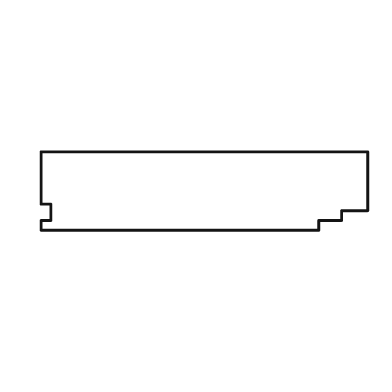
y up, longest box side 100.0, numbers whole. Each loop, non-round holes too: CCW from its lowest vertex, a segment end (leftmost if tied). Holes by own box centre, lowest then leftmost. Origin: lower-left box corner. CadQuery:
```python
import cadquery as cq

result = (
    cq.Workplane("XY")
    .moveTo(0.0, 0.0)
    .lineTo(85.0, 0.0)
    .lineTo(85.0, 3.0)
    .lineTo(92.0, 3.0)
    .lineTo(92.0, 6.0)
    .lineTo(100.0, 6.0)
    .lineTo(100.0, 24.0)
    .lineTo(0.0, 24.0)
    .lineTo(0.0, 8.0)
    .lineTo(3.0, 8.0)
    .lineTo(3.0, 3.0)
    .lineTo(0.0, 3.0)
    .close()
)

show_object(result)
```